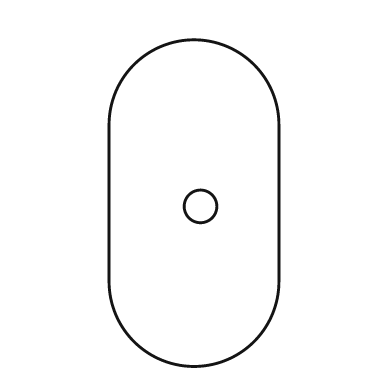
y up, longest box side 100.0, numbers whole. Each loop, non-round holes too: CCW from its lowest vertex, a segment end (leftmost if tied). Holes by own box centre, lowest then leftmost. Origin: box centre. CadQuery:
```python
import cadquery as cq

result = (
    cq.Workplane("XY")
    .moveTo(-26.0, -24.0)
    .threePointArc((0.0, -50.0), (26.0, -24.0))
    .lineTo(26.0, 24.0)
    .threePointArc((0.0, 50.0), (-26.0, 24.0))
    .close()
    .moveTo(2.0, -1.0)
    .circle(5.0)
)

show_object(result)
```